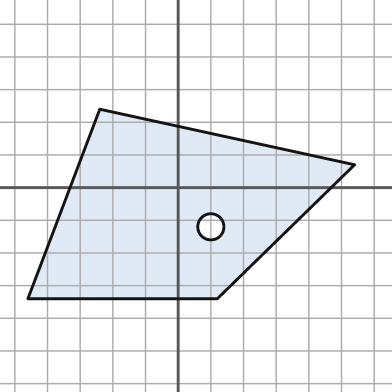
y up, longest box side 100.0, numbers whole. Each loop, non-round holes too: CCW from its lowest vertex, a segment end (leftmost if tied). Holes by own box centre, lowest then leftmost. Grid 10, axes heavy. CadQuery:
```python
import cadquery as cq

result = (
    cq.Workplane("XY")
    .moveTo(-46.0, -34.0)
    .lineTo(12.0, -34.0)
    .lineTo(54.0, 7.0)
    .lineTo(-24.0, 24.0)
    .close()
    .moveTo(10.0, -12.0)
    .circle(4.0)
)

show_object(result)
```